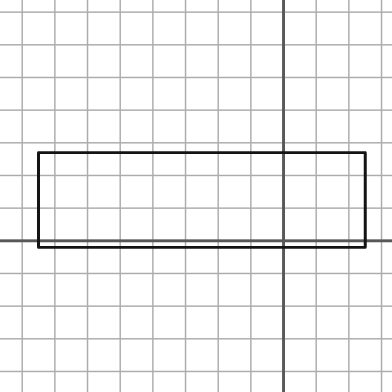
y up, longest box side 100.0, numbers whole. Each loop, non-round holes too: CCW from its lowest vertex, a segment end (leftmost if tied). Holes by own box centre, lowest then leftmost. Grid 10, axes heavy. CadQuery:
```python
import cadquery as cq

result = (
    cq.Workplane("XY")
    .moveTo(-75.0, -2.0)
    .lineTo(25.0, -2.0)
    .lineTo(25.0, 27.0)
    .lineTo(-75.0, 27.0)
    .close()
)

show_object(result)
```